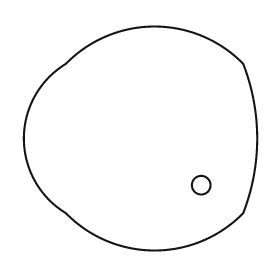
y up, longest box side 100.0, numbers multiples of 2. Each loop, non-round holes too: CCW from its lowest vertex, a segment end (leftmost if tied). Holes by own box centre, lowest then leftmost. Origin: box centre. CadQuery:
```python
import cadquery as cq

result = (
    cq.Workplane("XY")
    .moveTo(-32.0, -32.0)
    .threePointArc((6.0, -48.0), (44.0, -32.0))
    .threePointArc((50.0, 0.0), (44.0, 32.0))
    .threePointArc((6.0, 48.0), (-32.0, 32.0))
    .threePointArc((-50.0, 0.0), (-32.0, -32.0))
    .close()
    .moveTo(26.0, -20.0)
    .circle(4.0)
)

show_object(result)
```